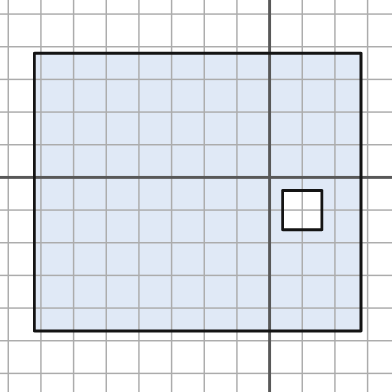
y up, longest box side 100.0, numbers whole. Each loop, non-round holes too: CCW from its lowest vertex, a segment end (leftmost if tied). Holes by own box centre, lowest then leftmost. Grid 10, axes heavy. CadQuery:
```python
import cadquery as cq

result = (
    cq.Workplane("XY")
    .moveTo(-72.0, -47.0)
    .lineTo(28.0, -47.0)
    .lineTo(28.0, 38.0)
    .lineTo(-72.0, 38.0)
    .close()
    .moveTo(4.0, -16.0)
    .lineTo(16.0, -16.0)
    .lineTo(16.0, -4.0)
    .lineTo(4.0, -4.0)
    .close()
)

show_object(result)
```